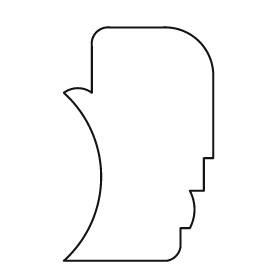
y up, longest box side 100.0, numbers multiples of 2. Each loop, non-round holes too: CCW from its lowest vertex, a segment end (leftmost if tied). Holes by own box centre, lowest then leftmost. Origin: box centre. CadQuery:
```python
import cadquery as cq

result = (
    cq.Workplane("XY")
    .moveTo(-32.0, -50.0)
    .lineTo(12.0, -50.0)
    .threePointArc((16.0, -48.0), (18.0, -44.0))
    .lineTo(18.0, -36.0)
    .lineTo(22.0, -36.0)
    .threePointArc((24.0, -28.0), (22.0, -20.0))
    .lineTo(28.0, -20.0)
    .lineTo(28.0, -6.0)
    .lineTo(32.0, -6.0)
    .lineTo(32.0, 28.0)
    .threePointArc((26.0, 44.0), (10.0, 50.0))
    .lineTo(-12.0, 50.0)
    .threePointArc((-18.0, 48.0), (-20.0, 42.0))
    .lineTo(-20.0, 22.0)
    .threePointArc((-26.0, 24.0), (-32.0, 22.0))
    .threePointArc((-16.0, -14.0), (-32.0, -50.0))
    .close()
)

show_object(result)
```